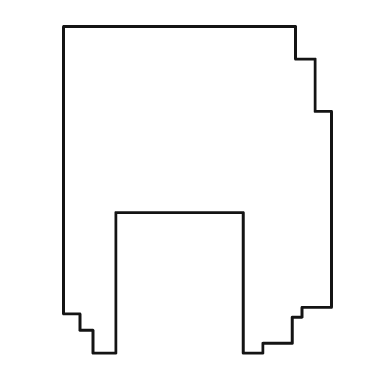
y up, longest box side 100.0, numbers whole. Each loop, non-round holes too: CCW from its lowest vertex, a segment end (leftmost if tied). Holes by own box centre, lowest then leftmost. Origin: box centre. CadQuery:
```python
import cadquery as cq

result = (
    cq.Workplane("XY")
    .moveTo(-32.0, -50.0)
    .lineTo(-25.0, -50.0)
    .lineTo(-25.0, -7.0)
    .lineTo(14.0, -7.0)
    .lineTo(14.0, -50.0)
    .lineTo(20.0, -50.0)
    .lineTo(20.0, -47.0)
    .lineTo(29.0, -47.0)
    .lineTo(29.0, -39.0)
    .lineTo(32.0, -39.0)
    .lineTo(32.0, -36.0)
    .lineTo(41.0, -36.0)
    .lineTo(41.0, 24.0)
    .lineTo(36.0, 24.0)
    .lineTo(36.0, 40.0)
    .lineTo(30.0, 40.0)
    .lineTo(30.0, 50.0)
    .lineTo(-41.0, 50.0)
    .lineTo(-41.0, -38.0)
    .lineTo(-36.0, -38.0)
    .lineTo(-36.0, -43.0)
    .lineTo(-32.0, -43.0)
    .close()
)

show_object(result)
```